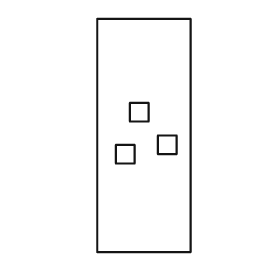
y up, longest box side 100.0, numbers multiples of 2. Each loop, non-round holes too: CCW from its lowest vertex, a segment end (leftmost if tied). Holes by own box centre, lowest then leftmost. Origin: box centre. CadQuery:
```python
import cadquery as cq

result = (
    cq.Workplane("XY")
    .moveTo(-20.0, -50.0)
    .lineTo(20.0, -50.0)
    .lineTo(20.0, 50.0)
    .lineTo(-20.0, 50.0)
    .close()
    .moveTo(-12.0, -12.0)
    .lineTo(-4.0, -12.0)
    .lineTo(-4.0, -4.0)
    .lineTo(-12.0, -4.0)
    .close()
    .moveTo(6.0, -8.0)
    .lineTo(14.0, -8.0)
    .lineTo(14.0, 0.0)
    .lineTo(6.0, 0.0)
    .close()
    .moveTo(-6.0, 6.0)
    .lineTo(2.0, 6.0)
    .lineTo(2.0, 14.0)
    .lineTo(-6.0, 14.0)
    .close()
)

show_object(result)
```